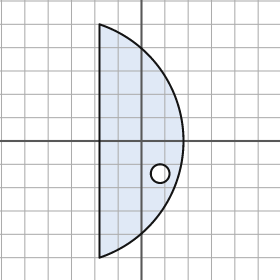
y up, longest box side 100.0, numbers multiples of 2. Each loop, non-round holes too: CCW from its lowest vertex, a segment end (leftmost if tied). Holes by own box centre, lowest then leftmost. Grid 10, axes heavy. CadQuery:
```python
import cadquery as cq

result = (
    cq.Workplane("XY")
    .moveTo(-18.0, -50.0)
    .threePointArc((18.0, 0.0), (-18.0, 50.0))
    .close()
    .moveTo(8.0, -14.0)
    .circle(4.0)
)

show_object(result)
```